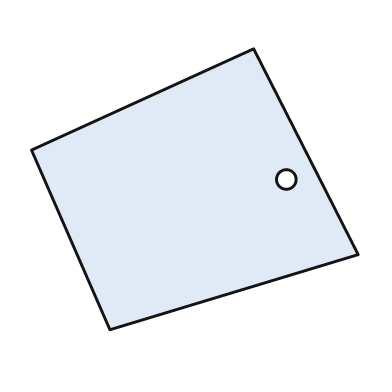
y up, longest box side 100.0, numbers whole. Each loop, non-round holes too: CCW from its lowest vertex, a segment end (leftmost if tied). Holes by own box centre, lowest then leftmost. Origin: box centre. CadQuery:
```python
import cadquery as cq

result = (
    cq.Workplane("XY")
    .moveTo(-26.0, -43.0)
    .lineTo(50.0, -20.0)
    .lineTo(18.0, 43.0)
    .lineTo(-50.0, 12.0)
    .close()
    .moveTo(28.0, 3.0)
    .circle(3.0)
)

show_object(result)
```